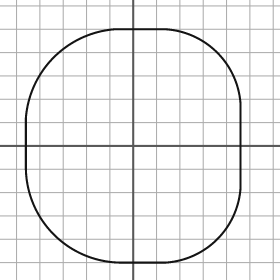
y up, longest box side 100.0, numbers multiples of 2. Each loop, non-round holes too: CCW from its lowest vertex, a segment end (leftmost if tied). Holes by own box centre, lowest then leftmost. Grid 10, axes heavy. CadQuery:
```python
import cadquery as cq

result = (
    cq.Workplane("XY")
    .moveTo(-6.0, -50.0)
    .lineTo(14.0, -50.0)
    .threePointArc((36.0, -40.0), (46.0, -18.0))
    .lineTo(46.0, 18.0)
    .threePointArc((36.0, 40.0), (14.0, 50.0))
    .lineTo(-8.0, 50.0)
    .threePointArc((-34.0, 38.0), (-46.0, 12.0))
    .lineTo(-46.0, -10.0)
    .threePointArc((-34.0, -38.0), (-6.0, -50.0))
    .close()
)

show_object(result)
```